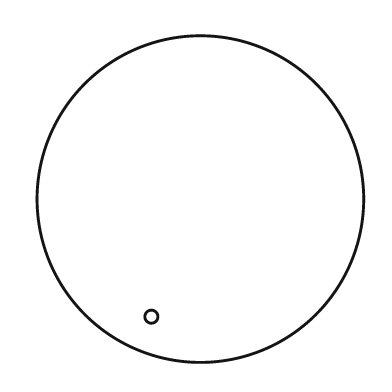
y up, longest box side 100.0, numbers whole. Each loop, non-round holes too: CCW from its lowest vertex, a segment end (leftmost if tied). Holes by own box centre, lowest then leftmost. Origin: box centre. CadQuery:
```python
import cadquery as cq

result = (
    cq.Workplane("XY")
    .moveTo(0.0, 0.0)
    .circle(50.0)
    .moveTo(-15.0, -36.0)
    .circle(2.0)
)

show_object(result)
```